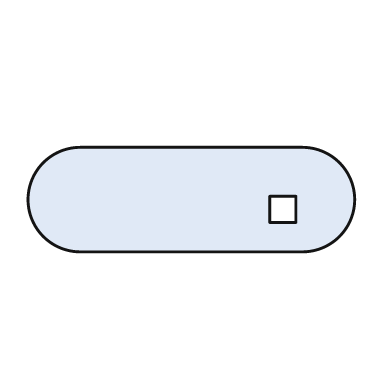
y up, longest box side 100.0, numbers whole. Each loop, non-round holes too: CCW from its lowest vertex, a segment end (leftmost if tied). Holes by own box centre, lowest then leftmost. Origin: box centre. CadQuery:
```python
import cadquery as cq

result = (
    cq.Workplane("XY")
    .moveTo(-34.0, -16.0)
    .lineTo(34.0, -16.0)
    .threePointArc((50.0, 0.0), (34.0, 16.0))
    .lineTo(-34.0, 16.0)
    .threePointArc((-50.0, 0.0), (-34.0, -16.0))
    .close()
    .moveTo(24.0, -7.0)
    .lineTo(32.0, -7.0)
    .lineTo(32.0, 1.0)
    .lineTo(24.0, 1.0)
    .close()
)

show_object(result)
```